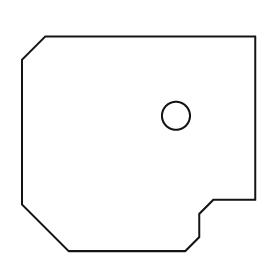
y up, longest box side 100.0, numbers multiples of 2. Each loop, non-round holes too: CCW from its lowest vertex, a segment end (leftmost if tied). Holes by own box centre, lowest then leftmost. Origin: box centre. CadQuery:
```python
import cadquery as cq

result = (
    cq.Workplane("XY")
    .moveTo(-30.0, -46.0)
    .lineTo(20.0, -46.0)
    .lineTo(26.0, -40.0)
    .lineTo(26.0, -30.0)
    .lineTo(32.0, -24.0)
    .lineTo(50.0, -24.0)
    .lineTo(50.0, 46.0)
    .lineTo(-40.0, 46.0)
    .lineTo(-50.0, 36.0)
    .lineTo(-50.0, -26.0)
    .close()
    .moveTo(16.0, 12.0)
    .circle(6.0)
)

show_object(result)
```